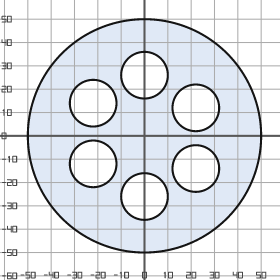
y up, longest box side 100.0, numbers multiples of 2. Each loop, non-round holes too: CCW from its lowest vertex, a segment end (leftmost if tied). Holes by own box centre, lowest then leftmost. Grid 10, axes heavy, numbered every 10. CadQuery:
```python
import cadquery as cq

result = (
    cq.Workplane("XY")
    .moveTo(0.0, 0.0)
    .circle(50.0)
    .moveTo(0.0, -26.0)
    .circle(10.0)
    .moveTo(22.0, -14.0)
    .circle(10.0)
    .moveTo(-22.0, -12.0)
    .circle(10.0)
    .moveTo(22.0, 12.0)
    .circle(10.0)
    .moveTo(-22.0, 14.0)
    .circle(10.0)
    .moveTo(0.0, 26.0)
    .circle(10.0)
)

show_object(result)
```